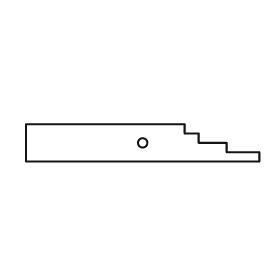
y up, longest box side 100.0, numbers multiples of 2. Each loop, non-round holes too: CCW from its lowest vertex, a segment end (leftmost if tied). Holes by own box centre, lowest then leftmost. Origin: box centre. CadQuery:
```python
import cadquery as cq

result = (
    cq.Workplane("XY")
    .moveTo(-50.0, -8.0)
    .lineTo(50.0, -8.0)
    .lineTo(50.0, -4.0)
    .lineTo(36.0, -4.0)
    .lineTo(36.0, 0.0)
    .lineTo(24.0, 0.0)
    .lineTo(24.0, 4.0)
    .lineTo(18.0, 4.0)
    .lineTo(18.0, 8.0)
    .lineTo(-50.0, 8.0)
    .close()
    .moveTo(0.0, 0.0)
    .circle(2.0)
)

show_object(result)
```